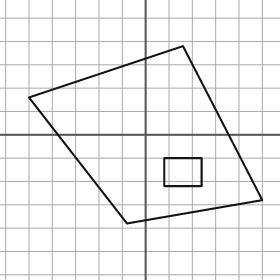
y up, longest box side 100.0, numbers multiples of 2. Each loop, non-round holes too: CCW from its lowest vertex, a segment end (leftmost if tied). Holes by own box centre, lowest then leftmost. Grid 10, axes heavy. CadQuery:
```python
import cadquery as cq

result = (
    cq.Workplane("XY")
    .moveTo(-8.0, -38.0)
    .lineTo(50.0, -28.0)
    .lineTo(16.0, 38.0)
    .lineTo(-50.0, 16.0)
    .close()
    .moveTo(8.0, -22.0)
    .lineTo(24.0, -22.0)
    .lineTo(24.0, -10.0)
    .lineTo(8.0, -10.0)
    .close()
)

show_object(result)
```